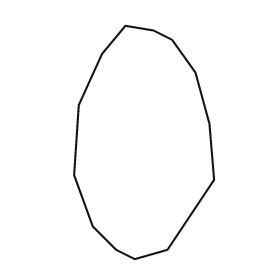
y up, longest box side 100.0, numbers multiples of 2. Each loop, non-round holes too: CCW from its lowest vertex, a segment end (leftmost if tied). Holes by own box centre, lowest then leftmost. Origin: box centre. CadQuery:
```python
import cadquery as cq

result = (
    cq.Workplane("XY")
    .moveTo(-4.0, -50.0)
    .lineTo(10.0, -46.0)
    .lineTo(30.0, -16.0)
    .lineTo(28.0, 8.0)
    .lineTo(22.0, 30.0)
    .lineTo(12.0, 44.0)
    .lineTo(4.0, 48.0)
    .lineTo(-8.0, 50.0)
    .lineTo(-18.0, 38.0)
    .lineTo(-28.0, 16.0)
    .lineTo(-30.0, -14.0)
    .lineTo(-22.0, -36.0)
    .lineTo(-12.0, -46.0)
    .close()
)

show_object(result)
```